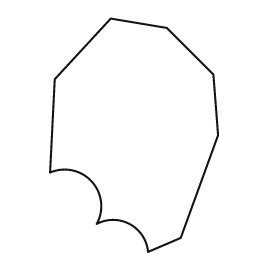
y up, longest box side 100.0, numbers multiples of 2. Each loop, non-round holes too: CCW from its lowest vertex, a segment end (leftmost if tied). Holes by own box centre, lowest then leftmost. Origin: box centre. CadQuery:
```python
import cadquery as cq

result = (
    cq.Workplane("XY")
    .moveTo(6.0, -50.0)
    .lineTo(20.0, -44.0)
    .lineTo(36.0, 0.0)
    .lineTo(34.0, 26.0)
    .lineTo(14.0, 46.0)
    .lineTo(-10.0, 50.0)
    .lineTo(-34.0, 24.0)
    .lineTo(-36.0, -16.0)
    .threePointArc((-18.0, -20.0), (-16.0, -38.0))
    .threePointArc((-2.0, -38.0), (6.0, -50.0))
    .close()
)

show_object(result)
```